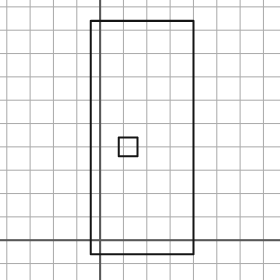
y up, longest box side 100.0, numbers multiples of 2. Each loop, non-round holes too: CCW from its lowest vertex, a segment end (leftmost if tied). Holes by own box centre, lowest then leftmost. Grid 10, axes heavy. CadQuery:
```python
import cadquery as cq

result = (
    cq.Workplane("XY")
    .moveTo(-4.0, -6.0)
    .lineTo(40.0, -6.0)
    .lineTo(40.0, 94.0)
    .lineTo(-4.0, 94.0)
    .close()
    .moveTo(8.0, 36.0)
    .lineTo(16.0, 36.0)
    .lineTo(16.0, 44.0)
    .lineTo(8.0, 44.0)
    .close()
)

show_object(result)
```